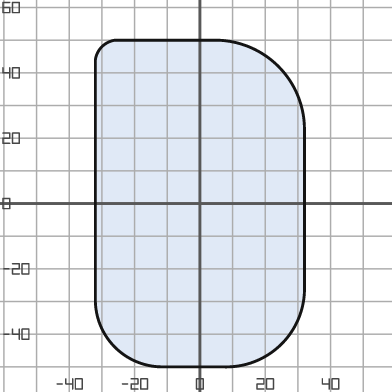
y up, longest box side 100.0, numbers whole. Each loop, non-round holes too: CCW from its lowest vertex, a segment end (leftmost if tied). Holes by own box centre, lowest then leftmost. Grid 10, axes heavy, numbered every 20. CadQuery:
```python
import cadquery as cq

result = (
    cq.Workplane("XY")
    .moveTo(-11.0, -50.0)
    .lineTo(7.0, -50.0)
    .threePointArc((25.0, -43.0), (32.0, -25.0))
    .lineTo(32.0, 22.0)
    .threePointArc((24.0, 42.0), (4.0, 50.0))
    .lineTo(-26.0, 50.0)
    .threePointArc((-30.0, 48.0), (-32.0, 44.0))
    .lineTo(-32.0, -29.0)
    .threePointArc((-26.0, -44.0), (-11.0, -50.0))
    .close()
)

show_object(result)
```